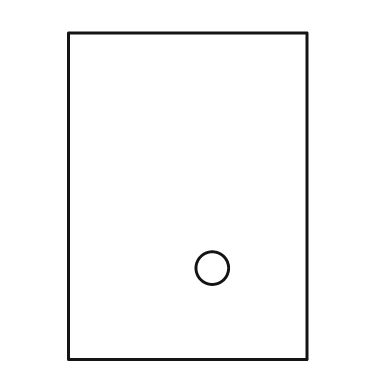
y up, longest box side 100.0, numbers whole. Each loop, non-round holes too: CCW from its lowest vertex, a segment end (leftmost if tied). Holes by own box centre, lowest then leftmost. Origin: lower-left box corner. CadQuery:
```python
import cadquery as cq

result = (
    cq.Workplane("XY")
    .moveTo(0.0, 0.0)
    .lineTo(73.0, 0.0)
    .lineTo(73.0, 100.0)
    .lineTo(0.0, 100.0)
    .close()
    .moveTo(44.0, 28.0)
    .circle(5.0)
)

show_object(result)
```